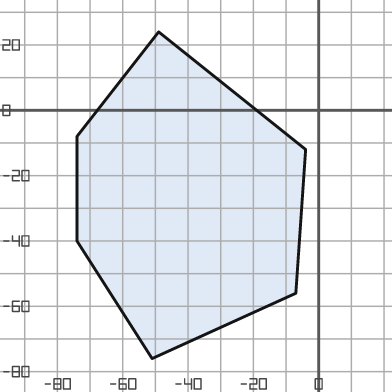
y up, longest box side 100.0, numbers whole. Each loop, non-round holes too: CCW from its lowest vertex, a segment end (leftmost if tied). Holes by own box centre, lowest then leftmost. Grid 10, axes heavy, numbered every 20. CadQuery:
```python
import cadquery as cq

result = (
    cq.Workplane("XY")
    .moveTo(-51.0, -76.0)
    .lineTo(-7.0, -56.0)
    .lineTo(-4.0, -12.0)
    .lineTo(-49.0, 24.0)
    .lineTo(-74.0, -8.0)
    .lineTo(-74.0, -40.0)
    .close()
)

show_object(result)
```